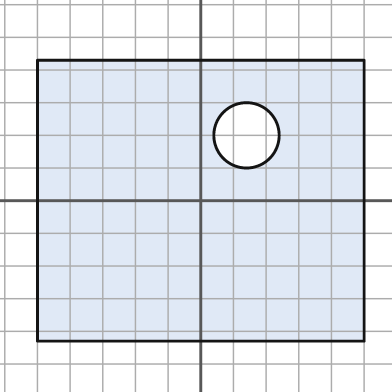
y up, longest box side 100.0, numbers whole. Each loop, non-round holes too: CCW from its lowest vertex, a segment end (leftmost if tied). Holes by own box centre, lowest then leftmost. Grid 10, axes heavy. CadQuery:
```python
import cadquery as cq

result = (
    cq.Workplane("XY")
    .moveTo(-50.0, -43.0)
    .lineTo(50.0, -43.0)
    .lineTo(50.0, 43.0)
    .lineTo(-50.0, 43.0)
    .close()
    .moveTo(14.0, 20.0)
    .circle(10.0)
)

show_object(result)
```